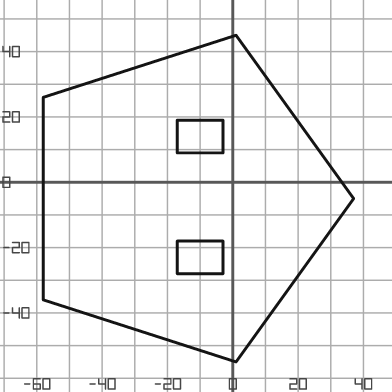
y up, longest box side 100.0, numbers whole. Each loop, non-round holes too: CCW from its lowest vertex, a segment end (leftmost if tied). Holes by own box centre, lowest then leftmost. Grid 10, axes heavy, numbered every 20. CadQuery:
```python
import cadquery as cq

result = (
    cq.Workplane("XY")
    .moveTo(1.0, -55.0)
    .lineTo(37.0, -5.0)
    .lineTo(1.0, 45.0)
    .lineTo(-58.0, 26.0)
    .lineTo(-58.0, -36.0)
    .close()
    .moveTo(-17.0, -28.0)
    .lineTo(-3.0, -28.0)
    .lineTo(-3.0, -18.0)
    .lineTo(-17.0, -18.0)
    .close()
    .moveTo(-17.0, 9.0)
    .lineTo(-3.0, 9.0)
    .lineTo(-3.0, 19.0)
    .lineTo(-17.0, 19.0)
    .close()
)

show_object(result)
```